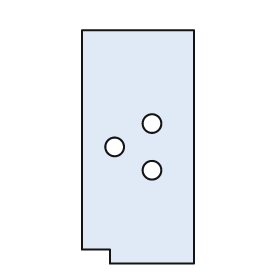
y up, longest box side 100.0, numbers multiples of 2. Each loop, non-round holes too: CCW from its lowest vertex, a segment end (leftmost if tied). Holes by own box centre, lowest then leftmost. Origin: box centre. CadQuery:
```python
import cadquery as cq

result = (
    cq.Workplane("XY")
    .moveTo(-12.0, -50.0)
    .lineTo(24.0, -50.0)
    .lineTo(24.0, 50.0)
    .lineTo(-24.0, 50.0)
    .lineTo(-24.0, -44.0)
    .lineTo(-12.0, -44.0)
    .close()
    .moveTo(6.0, -10.0)
    .circle(4.0)
    .moveTo(-10.0, 0.0)
    .circle(4.0)
    .moveTo(6.0, 10.0)
    .circle(4.0)
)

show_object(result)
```